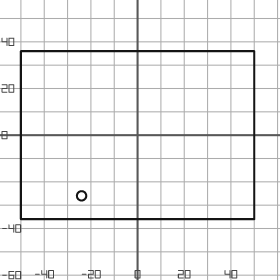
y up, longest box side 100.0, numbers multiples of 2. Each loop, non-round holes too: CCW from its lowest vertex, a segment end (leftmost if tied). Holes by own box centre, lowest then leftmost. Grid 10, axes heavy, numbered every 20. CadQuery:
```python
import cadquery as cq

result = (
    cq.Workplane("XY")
    .moveTo(-50.0, -36.0)
    .lineTo(50.0, -36.0)
    .lineTo(50.0, 36.0)
    .lineTo(-50.0, 36.0)
    .close()
    .moveTo(-24.0, -26.0)
    .circle(2.0)
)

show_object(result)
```